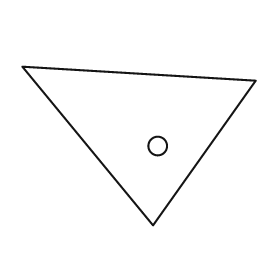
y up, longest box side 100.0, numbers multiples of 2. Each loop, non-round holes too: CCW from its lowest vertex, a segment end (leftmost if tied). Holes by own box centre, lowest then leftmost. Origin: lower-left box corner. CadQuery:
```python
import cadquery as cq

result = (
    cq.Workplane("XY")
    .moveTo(56.0, 0.0)
    .lineTo(100.0, 62.0)
    .lineTo(0.0, 68.0)
    .close()
    .moveTo(58.0, 34.0)
    .circle(4.0)
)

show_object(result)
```